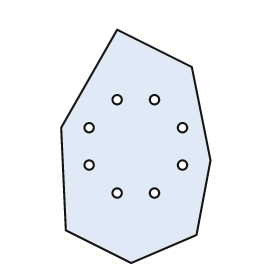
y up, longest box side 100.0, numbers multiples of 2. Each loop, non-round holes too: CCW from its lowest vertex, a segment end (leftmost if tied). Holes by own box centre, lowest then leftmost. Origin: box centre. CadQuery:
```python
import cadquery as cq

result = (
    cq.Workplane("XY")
    .moveTo(-2.0, -50.0)
    .lineTo(26.0, -38.0)
    .lineTo(32.0, -6.0)
    .lineTo(24.0, 34.0)
    .lineTo(-8.0, 50.0)
    .lineTo(-32.0, 8.0)
    .lineTo(-30.0, -36.0)
    .close()
    .moveTo(-8.0, -20.0)
    .circle(2.0)
    .moveTo(8.0, -20.0)
    .circle(2.0)
    .moveTo(-20.0, -8.0)
    .circle(2.0)
    .moveTo(20.0, -8.0)
    .circle(2.0)
    .moveTo(-20.0, 8.0)
    .circle(2.0)
    .moveTo(20.0, 8.0)
    .circle(2.0)
    .moveTo(-8.0, 20.0)
    .circle(2.0)
    .moveTo(8.0, 20.0)
    .circle(2.0)
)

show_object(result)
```